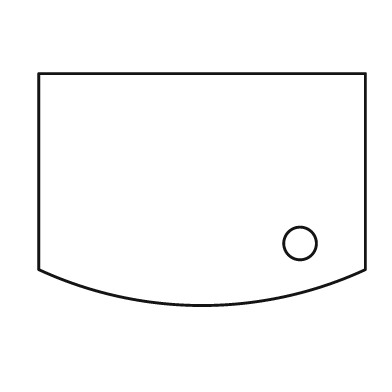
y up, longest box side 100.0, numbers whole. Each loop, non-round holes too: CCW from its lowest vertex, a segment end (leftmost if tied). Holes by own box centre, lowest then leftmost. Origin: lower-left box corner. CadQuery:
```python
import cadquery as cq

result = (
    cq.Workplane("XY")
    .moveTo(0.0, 11.0)
    .threePointArc((50.0, 0.0), (100.0, 11.0))
    .lineTo(100.0, 71.0)
    .lineTo(0.0, 71.0)
    .close()
    .moveTo(80.0, 19.0)
    .circle(5.0)
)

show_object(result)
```